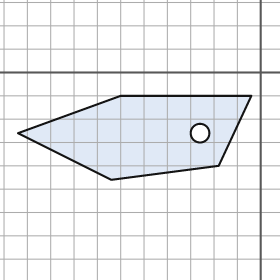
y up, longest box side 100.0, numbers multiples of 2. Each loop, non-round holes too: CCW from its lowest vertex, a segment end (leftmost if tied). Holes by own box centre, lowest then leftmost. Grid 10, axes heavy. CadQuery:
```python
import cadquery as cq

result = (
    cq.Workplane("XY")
    .moveTo(-64.0, -46.0)
    .lineTo(-18.0, -40.0)
    .lineTo(-4.0, -10.0)
    .lineTo(-60.0, -10.0)
    .lineTo(-104.0, -26.0)
    .close()
    .moveTo(-26.0, -26.0)
    .circle(4.0)
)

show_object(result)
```